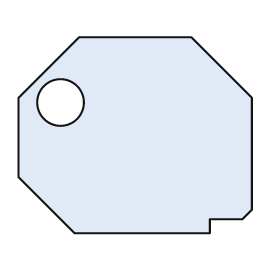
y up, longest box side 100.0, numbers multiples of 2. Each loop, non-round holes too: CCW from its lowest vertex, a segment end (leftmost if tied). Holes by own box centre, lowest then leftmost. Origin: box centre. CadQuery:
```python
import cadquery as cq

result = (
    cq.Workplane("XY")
    .moveTo(-26.0, -42.0)
    .lineTo(32.0, -42.0)
    .lineTo(32.0, -36.0)
    .lineTo(46.0, -36.0)
    .lineTo(50.0, -32.0)
    .lineTo(50.0, 16.0)
    .lineTo(24.0, 42.0)
    .lineTo(-24.0, 42.0)
    .lineTo(-50.0, 16.0)
    .lineTo(-50.0, -18.0)
    .close()
    .moveTo(-32.0, 14.0)
    .circle(10.0)
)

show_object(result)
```